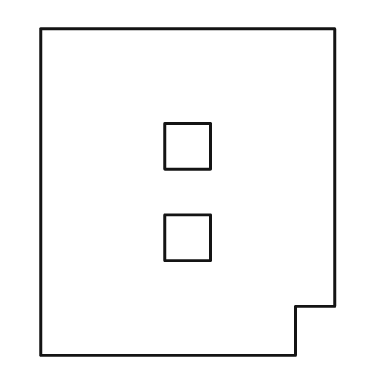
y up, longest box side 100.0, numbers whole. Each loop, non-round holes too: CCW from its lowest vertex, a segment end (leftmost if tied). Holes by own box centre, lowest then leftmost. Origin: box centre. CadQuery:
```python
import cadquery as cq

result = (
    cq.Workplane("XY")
    .moveTo(-45.0, -50.0)
    .lineTo(33.0, -50.0)
    .lineTo(33.0, -35.0)
    .lineTo(45.0, -35.0)
    .lineTo(45.0, 50.0)
    .lineTo(-45.0, 50.0)
    .close()
    .moveTo(-7.0, -21.0)
    .lineTo(7.0, -21.0)
    .lineTo(7.0, -7.0)
    .lineTo(-7.0, -7.0)
    .close()
    .moveTo(-7.0, 7.0)
    .lineTo(7.0, 7.0)
    .lineTo(7.0, 21.0)
    .lineTo(-7.0, 21.0)
    .close()
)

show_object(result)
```